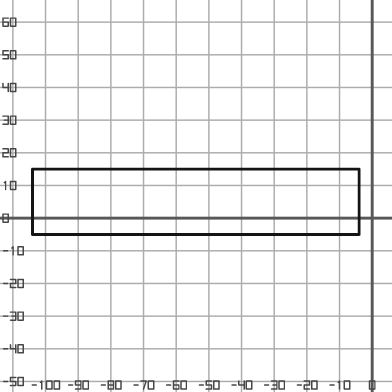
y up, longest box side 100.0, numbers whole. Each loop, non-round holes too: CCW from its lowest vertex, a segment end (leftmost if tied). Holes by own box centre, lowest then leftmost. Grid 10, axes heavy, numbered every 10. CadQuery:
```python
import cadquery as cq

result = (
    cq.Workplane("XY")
    .moveTo(-104.0, -5.0)
    .lineTo(-4.0, -5.0)
    .lineTo(-4.0, 15.0)
    .lineTo(-104.0, 15.0)
    .close()
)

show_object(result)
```